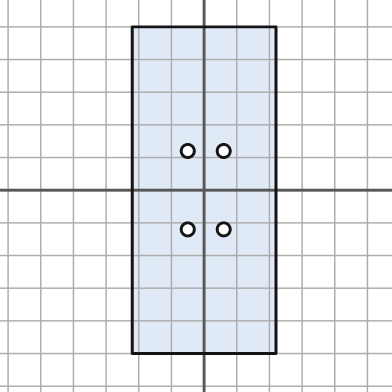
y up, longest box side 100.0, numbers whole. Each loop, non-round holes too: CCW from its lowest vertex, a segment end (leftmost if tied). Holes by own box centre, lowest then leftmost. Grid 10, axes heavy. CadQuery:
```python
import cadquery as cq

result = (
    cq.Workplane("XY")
    .moveTo(-22.0, -50.0)
    .lineTo(22.0, -50.0)
    .lineTo(22.0, 50.0)
    .lineTo(-22.0, 50.0)
    .close()
    .moveTo(-5.0, -12.0)
    .circle(2.0)
    .moveTo(6.0, -12.0)
    .circle(2.0)
    .moveTo(-5.0, 12.0)
    .circle(2.0)
    .moveTo(6.0, 12.0)
    .circle(2.0)
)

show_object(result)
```